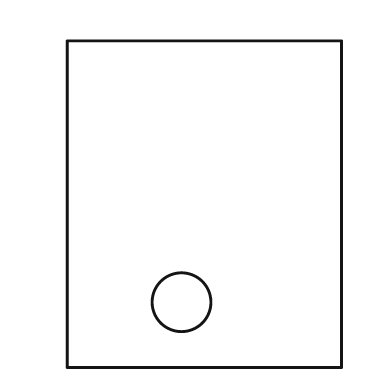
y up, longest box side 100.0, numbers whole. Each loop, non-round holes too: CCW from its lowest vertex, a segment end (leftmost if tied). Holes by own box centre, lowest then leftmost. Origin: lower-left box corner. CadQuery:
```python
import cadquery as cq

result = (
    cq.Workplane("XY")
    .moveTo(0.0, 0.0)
    .lineTo(84.0, 0.0)
    .lineTo(84.0, 100.0)
    .lineTo(0.0, 100.0)
    .close()
    .moveTo(35.0, 20.0)
    .circle(9.0)
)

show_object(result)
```